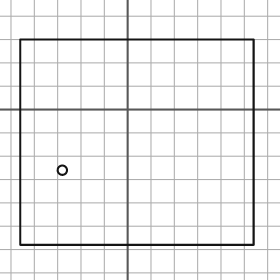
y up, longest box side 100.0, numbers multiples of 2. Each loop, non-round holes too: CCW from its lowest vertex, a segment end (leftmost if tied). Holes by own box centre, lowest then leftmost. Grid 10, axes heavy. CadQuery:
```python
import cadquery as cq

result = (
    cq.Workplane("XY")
    .moveTo(-46.0, -58.0)
    .lineTo(54.0, -58.0)
    .lineTo(54.0, 30.0)
    .lineTo(-46.0, 30.0)
    .close()
    .moveTo(-28.0, -26.0)
    .circle(2.0)
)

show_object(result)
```